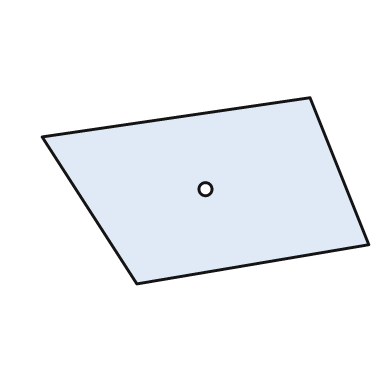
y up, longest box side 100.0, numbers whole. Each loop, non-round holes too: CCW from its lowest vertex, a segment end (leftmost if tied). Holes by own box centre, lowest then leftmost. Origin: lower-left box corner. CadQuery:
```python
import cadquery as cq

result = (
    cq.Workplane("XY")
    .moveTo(29.0, 0.0)
    .lineTo(100.0, 12.0)
    .lineTo(82.0, 57.0)
    .lineTo(0.0, 45.0)
    .close()
    .moveTo(50.0, 29.0)
    .circle(2.0)
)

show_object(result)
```